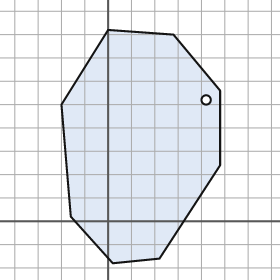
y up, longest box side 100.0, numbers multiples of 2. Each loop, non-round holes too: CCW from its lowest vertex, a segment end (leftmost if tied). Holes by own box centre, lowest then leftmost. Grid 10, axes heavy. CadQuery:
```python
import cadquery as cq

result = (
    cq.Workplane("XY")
    .moveTo(2.0, -18.0)
    .lineTo(22.0, -16.0)
    .lineTo(48.0, 24.0)
    .lineTo(48.0, 56.0)
    .lineTo(28.0, 80.0)
    .lineTo(0.0, 82.0)
    .lineTo(-20.0, 50.0)
    .lineTo(-16.0, 2.0)
    .close()
    .moveTo(42.0, 52.0)
    .circle(2.0)
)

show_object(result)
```